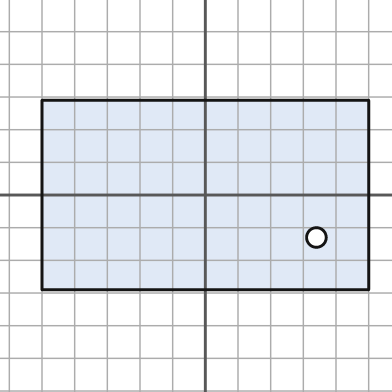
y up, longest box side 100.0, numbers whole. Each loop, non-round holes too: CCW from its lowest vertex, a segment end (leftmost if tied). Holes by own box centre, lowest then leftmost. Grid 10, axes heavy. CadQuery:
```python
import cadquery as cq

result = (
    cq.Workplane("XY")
    .moveTo(-50.0, -29.0)
    .lineTo(50.0, -29.0)
    .lineTo(50.0, 29.0)
    .lineTo(-50.0, 29.0)
    .close()
    .moveTo(34.0, -13.0)
    .circle(3.0)
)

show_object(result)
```